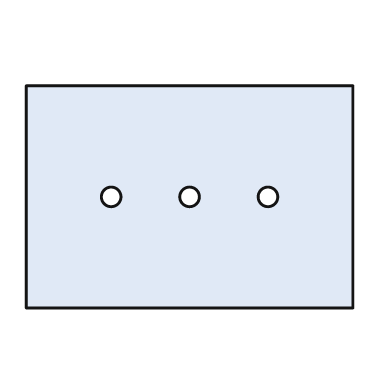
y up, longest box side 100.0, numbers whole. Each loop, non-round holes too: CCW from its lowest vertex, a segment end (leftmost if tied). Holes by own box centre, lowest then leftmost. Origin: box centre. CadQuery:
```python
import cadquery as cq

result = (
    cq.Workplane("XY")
    .moveTo(-50.0, -34.0)
    .lineTo(50.0, -34.0)
    .lineTo(50.0, 34.0)
    .lineTo(-50.0, 34.0)
    .close()
    .moveTo(-24.0, 0.0)
    .circle(3.0)
    .moveTo(0.0, 0.0)
    .circle(3.0)
    .moveTo(24.0, 0.0)
    .circle(3.0)
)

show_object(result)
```